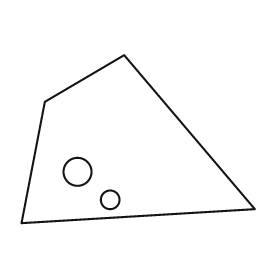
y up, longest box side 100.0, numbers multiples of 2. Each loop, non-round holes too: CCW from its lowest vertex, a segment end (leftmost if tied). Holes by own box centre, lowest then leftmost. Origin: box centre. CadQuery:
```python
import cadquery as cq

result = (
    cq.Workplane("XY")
    .moveTo(-50.0, -36.0)
    .lineTo(50.0, -30.0)
    .lineTo(-6.0, 36.0)
    .lineTo(-40.0, 16.0)
    .close()
    .moveTo(-12.0, -26.0)
    .circle(4.0)
    .moveTo(-26.0, -14.0)
    .circle(6.0)
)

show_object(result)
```